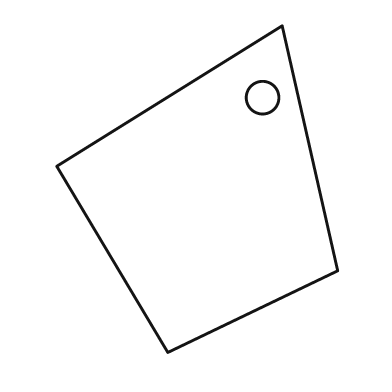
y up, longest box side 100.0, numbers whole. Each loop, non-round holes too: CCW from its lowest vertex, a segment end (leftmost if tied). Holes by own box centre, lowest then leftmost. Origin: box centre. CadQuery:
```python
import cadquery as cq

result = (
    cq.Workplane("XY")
    .moveTo(-9.0, -50.0)
    .lineTo(43.0, -25.0)
    .lineTo(26.0, 50.0)
    .lineTo(-43.0, 7.0)
    .close()
    .moveTo(20.0, 28.0)
    .circle(5.0)
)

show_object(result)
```